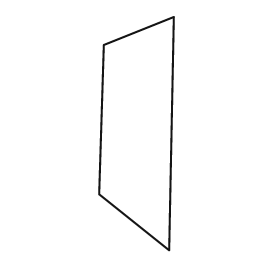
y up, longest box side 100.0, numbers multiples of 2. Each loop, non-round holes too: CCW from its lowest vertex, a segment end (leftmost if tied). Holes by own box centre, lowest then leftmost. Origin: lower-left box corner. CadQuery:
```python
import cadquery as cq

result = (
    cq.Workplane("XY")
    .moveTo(30.0, 0.0)
    .lineTo(32.0, 100.0)
    .lineTo(2.0, 88.0)
    .lineTo(0.0, 24.0)
    .close()
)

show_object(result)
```